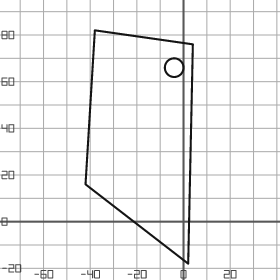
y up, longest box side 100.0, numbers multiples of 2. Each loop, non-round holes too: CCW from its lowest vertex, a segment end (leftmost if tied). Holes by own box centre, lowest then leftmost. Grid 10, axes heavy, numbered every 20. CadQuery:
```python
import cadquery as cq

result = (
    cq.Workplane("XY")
    .moveTo(2.0, -18.0)
    .lineTo(4.0, 76.0)
    .lineTo(-38.0, 82.0)
    .lineTo(-42.0, 16.0)
    .close()
    .moveTo(-4.0, 66.0)
    .circle(4.0)
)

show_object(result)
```